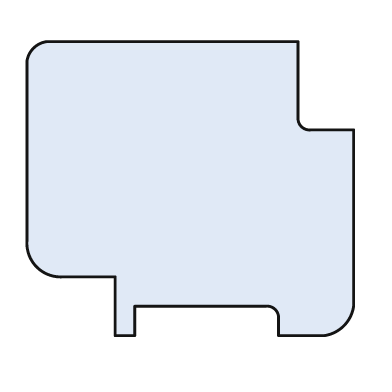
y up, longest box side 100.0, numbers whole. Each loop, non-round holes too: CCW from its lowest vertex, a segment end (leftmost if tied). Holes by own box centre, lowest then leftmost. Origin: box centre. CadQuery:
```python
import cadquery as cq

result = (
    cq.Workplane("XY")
    .moveTo(-23.0, -45.0)
    .lineTo(-17.0, -45.0)
    .lineTo(-17.0, -36.0)
    .lineTo(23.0, -36.0)
    .threePointArc((26.0, -37.0), (27.0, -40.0))
    .lineTo(27.0, -45.0)
    .lineTo(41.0, -45.0)
    .threePointArc((47.0, -42.0), (50.0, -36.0))
    .lineTo(50.0, 18.0)
    .lineTo(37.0, 18.0)
    .threePointArc((34.0, 19.0), (33.0, 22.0))
    .lineTo(33.0, 45.0)
    .lineTo(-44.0, 45.0)
    .threePointArc((-48.0, 43.0), (-50.0, 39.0))
    .lineTo(-50.0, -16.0)
    .threePointArc((-47.0, -24.0), (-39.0, -27.0))
    .lineTo(-23.0, -27.0)
    .close()
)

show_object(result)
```